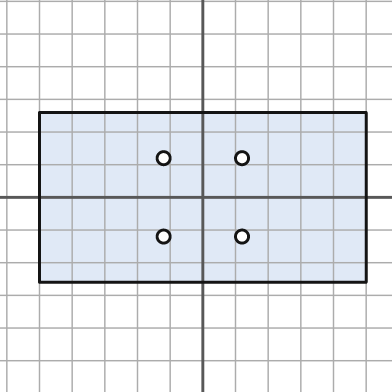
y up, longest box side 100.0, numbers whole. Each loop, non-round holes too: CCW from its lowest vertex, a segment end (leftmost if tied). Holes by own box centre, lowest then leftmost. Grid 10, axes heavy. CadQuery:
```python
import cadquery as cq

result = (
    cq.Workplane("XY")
    .moveTo(-50.0, -26.0)
    .lineTo(50.0, -26.0)
    .lineTo(50.0, 26.0)
    .lineTo(-50.0, 26.0)
    .close()
    .moveTo(-12.0, -12.0)
    .circle(2.0)
    .moveTo(12.0, -12.0)
    .circle(2.0)
    .moveTo(-12.0, 12.0)
    .circle(2.0)
    .moveTo(12.0, 12.0)
    .circle(2.0)
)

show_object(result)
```